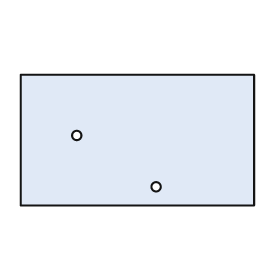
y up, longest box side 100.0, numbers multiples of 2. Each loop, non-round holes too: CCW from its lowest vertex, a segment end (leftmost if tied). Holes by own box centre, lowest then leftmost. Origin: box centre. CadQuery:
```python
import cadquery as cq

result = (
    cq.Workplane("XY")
    .moveTo(-50.0, -28.0)
    .lineTo(50.0, -28.0)
    .lineTo(50.0, 28.0)
    .lineTo(-50.0, 28.0)
    .close()
    .moveTo(8.0, -20.0)
    .circle(2.0)
    .moveTo(-26.0, 2.0)
    .circle(2.0)
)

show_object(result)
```